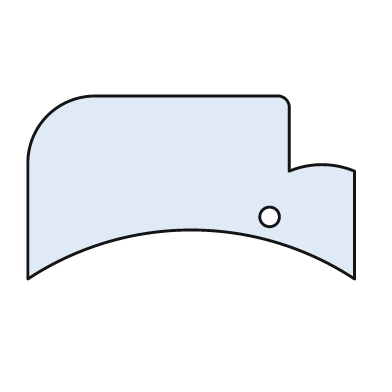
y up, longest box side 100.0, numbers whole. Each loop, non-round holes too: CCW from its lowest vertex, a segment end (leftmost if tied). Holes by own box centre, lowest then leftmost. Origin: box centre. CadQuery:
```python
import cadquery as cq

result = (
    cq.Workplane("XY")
    .moveTo(-50.0, -28.0)
    .threePointArc((0.0, -13.0), (50.0, -28.0))
    .lineTo(50.0, 5.0)
    .threePointArc((40.0, 7.0), (30.0, 5.0))
    .lineTo(30.0, 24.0)
    .threePointArc((29.0, 27.0), (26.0, 28.0))
    .lineTo(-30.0, 28.0)
    .threePointArc((-44.0, 22.0), (-50.0, 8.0))
    .close()
    .moveTo(24.0, -9.0)
    .circle(3.0)
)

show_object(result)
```